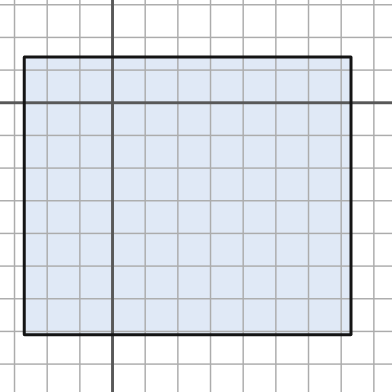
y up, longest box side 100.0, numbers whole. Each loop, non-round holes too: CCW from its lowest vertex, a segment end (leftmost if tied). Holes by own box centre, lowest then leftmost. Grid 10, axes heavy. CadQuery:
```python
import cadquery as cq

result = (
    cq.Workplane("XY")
    .moveTo(-27.0, -71.0)
    .lineTo(73.0, -71.0)
    .lineTo(73.0, 14.0)
    .lineTo(-27.0, 14.0)
    .close()
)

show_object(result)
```